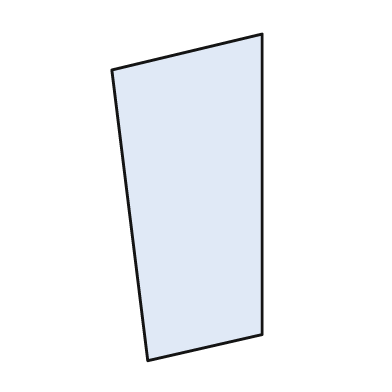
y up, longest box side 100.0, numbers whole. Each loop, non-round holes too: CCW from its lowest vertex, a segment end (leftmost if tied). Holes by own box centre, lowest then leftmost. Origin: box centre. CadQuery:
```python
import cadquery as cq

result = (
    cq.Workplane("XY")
    .moveTo(-12.0, -50.0)
    .lineTo(23.0, -42.0)
    .lineTo(23.0, 50.0)
    .lineTo(-23.0, 39.0)
    .close()
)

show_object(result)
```